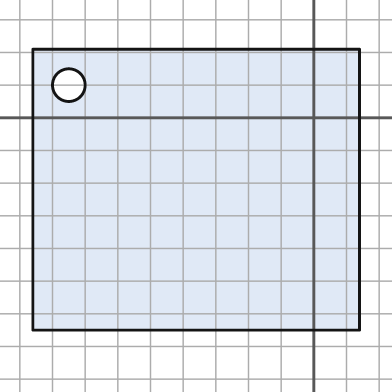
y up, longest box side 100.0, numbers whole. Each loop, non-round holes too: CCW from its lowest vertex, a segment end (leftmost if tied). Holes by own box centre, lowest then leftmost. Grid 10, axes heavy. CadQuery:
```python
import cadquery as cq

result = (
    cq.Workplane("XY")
    .moveTo(-86.0, -65.0)
    .lineTo(14.0, -65.0)
    .lineTo(14.0, 21.0)
    .lineTo(-86.0, 21.0)
    .close()
    .moveTo(-75.0, 10.0)
    .circle(5.0)
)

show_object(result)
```